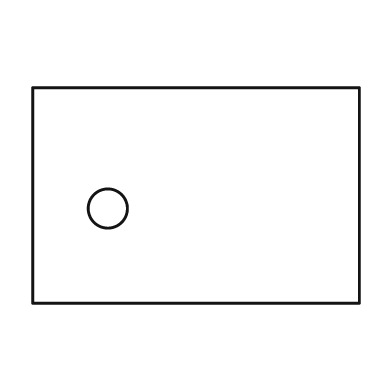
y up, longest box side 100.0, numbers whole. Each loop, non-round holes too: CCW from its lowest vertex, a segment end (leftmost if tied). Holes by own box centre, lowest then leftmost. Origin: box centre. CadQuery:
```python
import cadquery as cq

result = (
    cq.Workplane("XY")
    .moveTo(-50.0, -33.0)
    .lineTo(50.0, -33.0)
    .lineTo(50.0, 33.0)
    .lineTo(-50.0, 33.0)
    .close()
    .moveTo(-27.0, -4.0)
    .circle(6.0)
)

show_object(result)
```